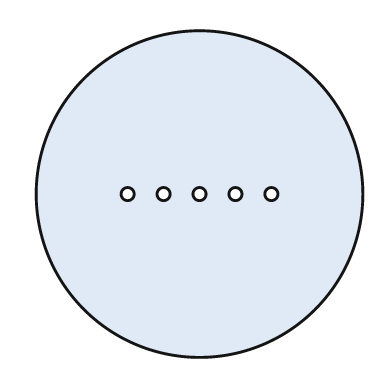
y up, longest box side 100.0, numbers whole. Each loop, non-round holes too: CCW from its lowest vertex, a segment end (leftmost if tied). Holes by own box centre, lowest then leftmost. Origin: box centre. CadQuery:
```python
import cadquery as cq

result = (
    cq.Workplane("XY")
    .moveTo(0.0, 0.0)
    .circle(50.0)
    .moveTo(-22.0, 0.0)
    .circle(2.0)
    .moveTo(-11.0, 0.0)
    .circle(2.0)
    .moveTo(0.0, 0.0)
    .circle(2.0)
    .moveTo(11.0, 0.0)
    .circle(2.0)
    .moveTo(22.0, 0.0)
    .circle(2.0)
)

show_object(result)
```